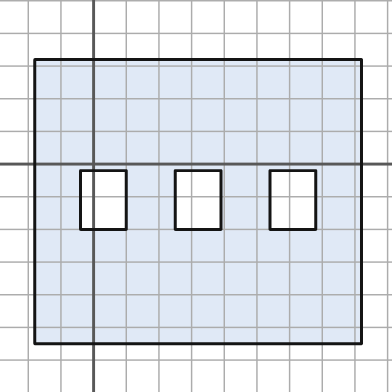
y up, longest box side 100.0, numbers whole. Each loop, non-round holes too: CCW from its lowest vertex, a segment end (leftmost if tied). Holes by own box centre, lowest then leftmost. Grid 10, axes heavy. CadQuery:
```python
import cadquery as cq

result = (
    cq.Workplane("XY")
    .moveTo(-18.0, -55.0)
    .lineTo(82.0, -55.0)
    .lineTo(82.0, 32.0)
    .lineTo(-18.0, 32.0)
    .close()
    .moveTo(-4.0, -20.0)
    .lineTo(10.0, -20.0)
    .lineTo(10.0, -2.0)
    .lineTo(-4.0, -2.0)
    .close()
    .moveTo(25.0, -20.0)
    .lineTo(39.0, -20.0)
    .lineTo(39.0, -2.0)
    .lineTo(25.0, -2.0)
    .close()
    .moveTo(54.0, -20.0)
    .lineTo(68.0, -20.0)
    .lineTo(68.0, -2.0)
    .lineTo(54.0, -2.0)
    .close()
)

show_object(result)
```